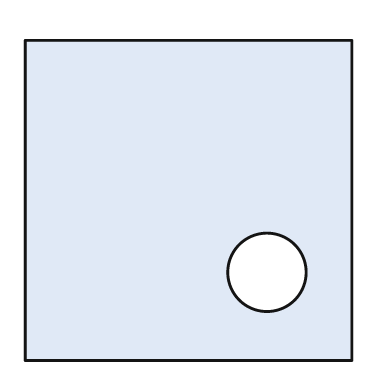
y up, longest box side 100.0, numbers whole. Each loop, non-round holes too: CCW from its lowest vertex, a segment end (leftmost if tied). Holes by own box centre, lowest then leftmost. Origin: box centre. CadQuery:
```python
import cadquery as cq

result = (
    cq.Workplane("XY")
    .moveTo(-50.0, -49.0)
    .lineTo(50.0, -49.0)
    .lineTo(50.0, 49.0)
    .lineTo(-50.0, 49.0)
    .close()
    .moveTo(24.0, -22.0)
    .circle(12.0)
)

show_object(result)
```